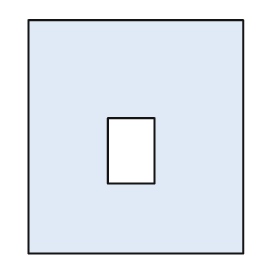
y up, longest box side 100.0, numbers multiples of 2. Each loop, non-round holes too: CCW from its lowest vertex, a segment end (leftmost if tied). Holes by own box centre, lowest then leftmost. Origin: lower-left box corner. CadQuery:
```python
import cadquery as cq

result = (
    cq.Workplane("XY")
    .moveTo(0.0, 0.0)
    .lineTo(92.0, 0.0)
    .lineTo(92.0, 100.0)
    .lineTo(0.0, 100.0)
    .close()
    .moveTo(34.0, 30.0)
    .lineTo(54.0, 30.0)
    .lineTo(54.0, 58.0)
    .lineTo(34.0, 58.0)
    .close()
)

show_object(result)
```